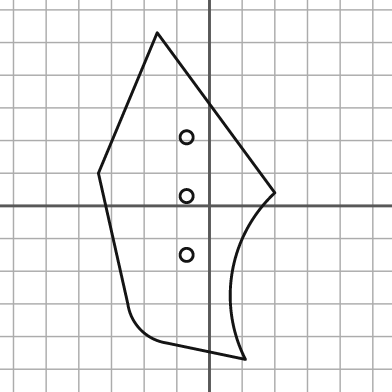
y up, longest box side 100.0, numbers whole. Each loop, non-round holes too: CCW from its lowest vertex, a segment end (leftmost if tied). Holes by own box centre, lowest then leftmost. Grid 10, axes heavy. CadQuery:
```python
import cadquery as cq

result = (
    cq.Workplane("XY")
    .moveTo(11.0, -47.0)
    .threePointArc((7.0, -20.0), (20.0, 4.0))
    .lineTo(-16.0, 53.0)
    .lineTo(-34.0, 10.0)
    .lineTo(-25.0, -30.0)
    .threePointArc((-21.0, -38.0), (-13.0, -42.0))
    .close()
    .moveTo(-7.0, -15.0)
    .circle(2.0)
    .moveTo(-7.0, 3.0)
    .circle(2.0)
    .moveTo(-7.0, 21.0)
    .circle(2.0)
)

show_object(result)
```